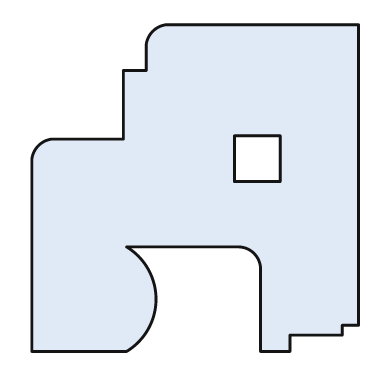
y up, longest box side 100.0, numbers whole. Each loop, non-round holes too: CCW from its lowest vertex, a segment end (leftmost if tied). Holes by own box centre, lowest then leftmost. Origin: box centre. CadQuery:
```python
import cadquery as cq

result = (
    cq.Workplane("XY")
    .moveTo(-50.0, -50.0)
    .lineTo(-21.0, -50.0)
    .threePointArc((-12.0, -34.0), (-21.0, -18.0))
    .lineTo(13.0, -18.0)
    .threePointArc((18.0, -20.0), (20.0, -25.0))
    .lineTo(20.0, -50.0)
    .lineTo(29.0, -50.0)
    .lineTo(29.0, -45.0)
    .lineTo(45.0, -45.0)
    .lineTo(45.0, -42.0)
    .lineTo(50.0, -42.0)
    .lineTo(50.0, 50.0)
    .lineTo(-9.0, 50.0)
    .threePointArc((-13.0, 48.0), (-15.0, 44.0))
    .lineTo(-15.0, 36.0)
    .lineTo(-22.0, 36.0)
    .lineTo(-22.0, 15.0)
    .lineTo(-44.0, 15.0)
    .threePointArc((-48.0, 13.0), (-50.0, 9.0))
    .close()
    .moveTo(12.0, 2.0)
    .lineTo(26.0, 2.0)
    .lineTo(26.0, 16.0)
    .lineTo(12.0, 16.0)
    .close()
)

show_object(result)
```